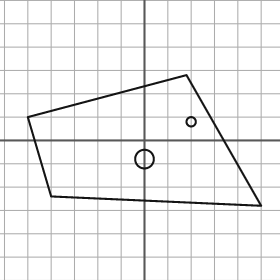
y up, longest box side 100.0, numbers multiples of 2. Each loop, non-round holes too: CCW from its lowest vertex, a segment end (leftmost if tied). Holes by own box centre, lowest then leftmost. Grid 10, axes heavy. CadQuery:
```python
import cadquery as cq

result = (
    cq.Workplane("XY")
    .moveTo(50.0, -28.0)
    .lineTo(18.0, 28.0)
    .lineTo(-50.0, 10.0)
    .lineTo(-40.0, -24.0)
    .close()
    .moveTo(0.0, -8.0)
    .circle(4.0)
    .moveTo(20.0, 8.0)
    .circle(2.0)
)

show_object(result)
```